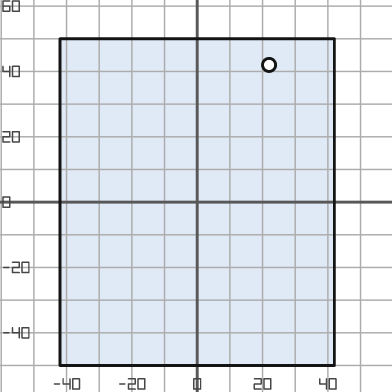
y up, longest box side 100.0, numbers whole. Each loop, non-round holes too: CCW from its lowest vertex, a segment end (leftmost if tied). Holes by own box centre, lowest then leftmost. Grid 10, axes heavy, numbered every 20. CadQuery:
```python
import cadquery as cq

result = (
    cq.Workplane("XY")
    .moveTo(-42.0, -50.0)
    .lineTo(42.0, -50.0)
    .lineTo(42.0, 50.0)
    .lineTo(-42.0, 50.0)
    .close()
    .moveTo(22.0, 42.0)
    .circle(2.0)
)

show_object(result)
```